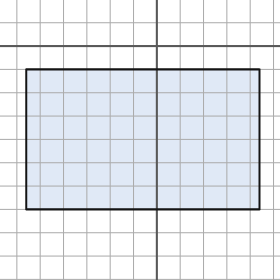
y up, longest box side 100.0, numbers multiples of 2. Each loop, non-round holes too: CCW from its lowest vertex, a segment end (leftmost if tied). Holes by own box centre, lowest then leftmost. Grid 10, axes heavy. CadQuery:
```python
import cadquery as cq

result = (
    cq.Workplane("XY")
    .moveTo(-56.0, -70.0)
    .lineTo(44.0, -70.0)
    .lineTo(44.0, -10.0)
    .lineTo(-56.0, -10.0)
    .close()
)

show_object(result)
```